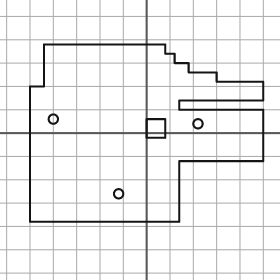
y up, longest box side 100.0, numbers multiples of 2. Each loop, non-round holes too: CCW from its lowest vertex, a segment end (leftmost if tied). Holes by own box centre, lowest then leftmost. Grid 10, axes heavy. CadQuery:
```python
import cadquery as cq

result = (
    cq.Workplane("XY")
    .moveTo(-50.0, -38.0)
    .lineTo(14.0, -38.0)
    .lineTo(14.0, -12.0)
    .lineTo(50.0, -12.0)
    .lineTo(50.0, 10.0)
    .lineTo(14.0, 10.0)
    .lineTo(14.0, 14.0)
    .lineTo(50.0, 14.0)
    .lineTo(50.0, 22.0)
    .lineTo(30.0, 22.0)
    .lineTo(30.0, 26.0)
    .lineTo(18.0, 26.0)
    .lineTo(18.0, 30.0)
    .lineTo(12.0, 30.0)
    .lineTo(12.0, 34.0)
    .lineTo(8.0, 34.0)
    .lineTo(8.0, 38.0)
    .lineTo(-44.0, 38.0)
    .lineTo(-44.0, 20.0)
    .lineTo(-50.0, 20.0)
    .close()
    .moveTo(-12.0, -26.0)
    .circle(2.0)
    .moveTo(0.0, -2.0)
    .lineTo(8.0, -2.0)
    .lineTo(8.0, 6.0)
    .lineTo(0.0, 6.0)
    .close()
    .moveTo(22.0, 4.0)
    .circle(2.0)
    .moveTo(-40.0, 6.0)
    .circle(2.0)
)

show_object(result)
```